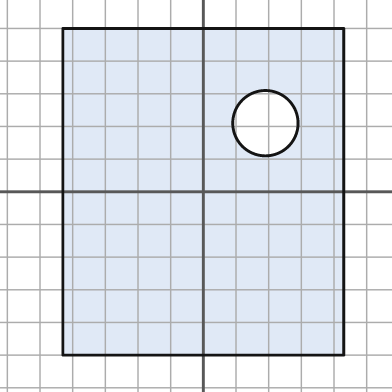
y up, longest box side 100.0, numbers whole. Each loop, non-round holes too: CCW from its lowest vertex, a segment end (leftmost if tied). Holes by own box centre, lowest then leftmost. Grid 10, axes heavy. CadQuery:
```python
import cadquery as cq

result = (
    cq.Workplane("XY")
    .moveTo(-43.0, -50.0)
    .lineTo(43.0, -50.0)
    .lineTo(43.0, 50.0)
    .lineTo(-43.0, 50.0)
    .close()
    .moveTo(19.0, 21.0)
    .circle(10.0)
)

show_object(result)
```